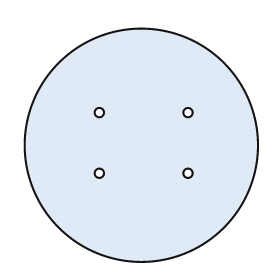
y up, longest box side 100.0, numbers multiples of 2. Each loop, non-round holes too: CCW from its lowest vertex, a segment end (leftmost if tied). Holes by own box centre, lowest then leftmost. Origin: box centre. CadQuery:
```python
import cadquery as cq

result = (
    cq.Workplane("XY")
    .moveTo(0.0, 0.0)
    .circle(50.0)
    .moveTo(-18.0, -12.0)
    .circle(2.0)
    .moveTo(20.0, -12.0)
    .circle(2.0)
    .moveTo(-18.0, 14.0)
    .circle(2.0)
    .moveTo(20.0, 14.0)
    .circle(2.0)
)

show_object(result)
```